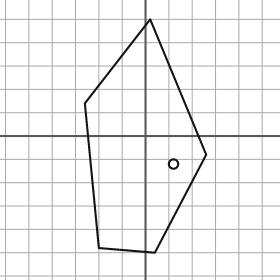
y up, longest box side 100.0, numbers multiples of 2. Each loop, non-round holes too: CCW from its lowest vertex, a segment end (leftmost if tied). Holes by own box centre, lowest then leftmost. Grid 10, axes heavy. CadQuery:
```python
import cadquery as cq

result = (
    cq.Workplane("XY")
    .moveTo(4.0, -50.0)
    .lineTo(26.0, -8.0)
    .lineTo(2.0, 50.0)
    .lineTo(-26.0, 14.0)
    .lineTo(-20.0, -48.0)
    .close()
    .moveTo(12.0, -12.0)
    .circle(2.0)
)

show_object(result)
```